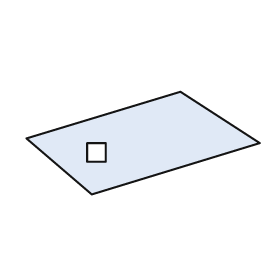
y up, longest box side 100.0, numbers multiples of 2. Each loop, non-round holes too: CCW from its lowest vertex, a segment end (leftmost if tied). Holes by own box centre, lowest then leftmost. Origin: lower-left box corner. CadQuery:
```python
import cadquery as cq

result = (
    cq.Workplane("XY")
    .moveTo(28.0, 0.0)
    .lineTo(100.0, 22.0)
    .lineTo(66.0, 44.0)
    .lineTo(0.0, 24.0)
    .close()
    .moveTo(26.0, 14.0)
    .lineTo(34.0, 14.0)
    .lineTo(34.0, 22.0)
    .lineTo(26.0, 22.0)
    .close()
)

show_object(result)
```